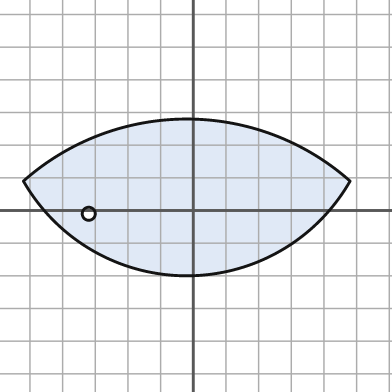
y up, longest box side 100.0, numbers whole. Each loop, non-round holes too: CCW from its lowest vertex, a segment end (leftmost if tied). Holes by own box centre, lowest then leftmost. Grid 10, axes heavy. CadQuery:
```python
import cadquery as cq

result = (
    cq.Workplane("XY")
    .moveTo(-52.0, 9.0)
    .threePointArc((-2.0, -20.0), (48.0, 9.0))
    .threePointArc((-2.0, 28.0), (-52.0, 9.0))
    .close()
    .moveTo(-32.0, -1.0)
    .circle(2.0)
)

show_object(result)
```